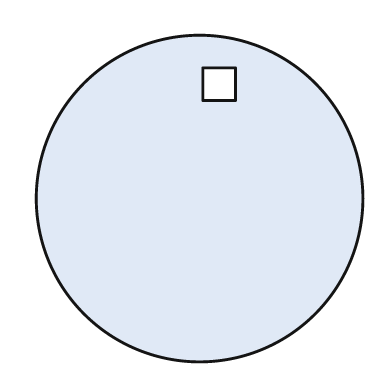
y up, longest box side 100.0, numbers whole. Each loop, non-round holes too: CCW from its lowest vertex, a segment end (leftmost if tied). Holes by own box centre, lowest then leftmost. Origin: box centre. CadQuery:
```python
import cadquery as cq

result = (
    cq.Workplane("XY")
    .moveTo(0.0, 0.0)
    .circle(50.0)
    .moveTo(1.0, 30.0)
    .lineTo(11.0, 30.0)
    .lineTo(11.0, 40.0)
    .lineTo(1.0, 40.0)
    .close()
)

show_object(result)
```